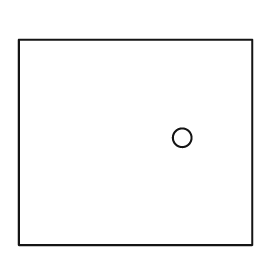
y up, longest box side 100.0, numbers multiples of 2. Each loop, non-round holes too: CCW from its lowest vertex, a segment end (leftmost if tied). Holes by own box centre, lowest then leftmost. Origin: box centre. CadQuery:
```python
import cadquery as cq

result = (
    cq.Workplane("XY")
    .moveTo(-50.0, -44.0)
    .lineTo(50.0, -44.0)
    .lineTo(50.0, 44.0)
    .lineTo(-50.0, 44.0)
    .close()
    .moveTo(20.0, 2.0)
    .circle(4.0)
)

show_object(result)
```